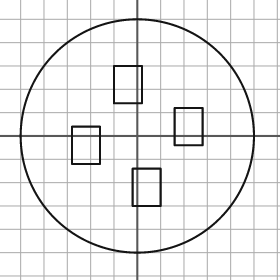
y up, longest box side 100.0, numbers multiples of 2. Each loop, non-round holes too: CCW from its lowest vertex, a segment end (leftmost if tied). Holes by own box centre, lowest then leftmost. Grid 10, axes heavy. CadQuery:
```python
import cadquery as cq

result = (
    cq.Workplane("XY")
    .moveTo(0.0, 0.0)
    .circle(50.0)
    .moveTo(-2.0, -30.0)
    .lineTo(10.0, -30.0)
    .lineTo(10.0, -14.0)
    .lineTo(-2.0, -14.0)
    .close()
    .moveTo(-28.0, -12.0)
    .lineTo(-16.0, -12.0)
    .lineTo(-16.0, 4.0)
    .lineTo(-28.0, 4.0)
    .close()
    .moveTo(16.0, -4.0)
    .lineTo(28.0, -4.0)
    .lineTo(28.0, 12.0)
    .lineTo(16.0, 12.0)
    .close()
    .moveTo(-10.0, 14.0)
    .lineTo(2.0, 14.0)
    .lineTo(2.0, 30.0)
    .lineTo(-10.0, 30.0)
    .close()
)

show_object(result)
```